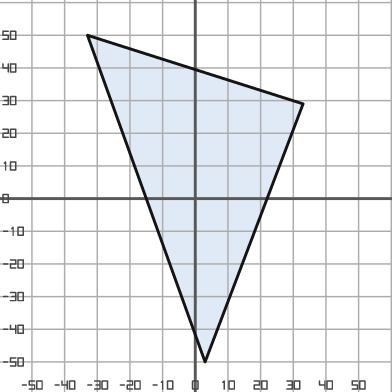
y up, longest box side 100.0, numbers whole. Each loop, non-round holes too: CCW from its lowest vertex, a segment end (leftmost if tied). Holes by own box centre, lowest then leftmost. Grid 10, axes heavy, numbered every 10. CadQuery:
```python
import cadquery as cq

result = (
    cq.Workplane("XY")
    .moveTo(3.0, -50.0)
    .lineTo(33.0, 29.0)
    .lineTo(-33.0, 50.0)
    .close()
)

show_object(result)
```